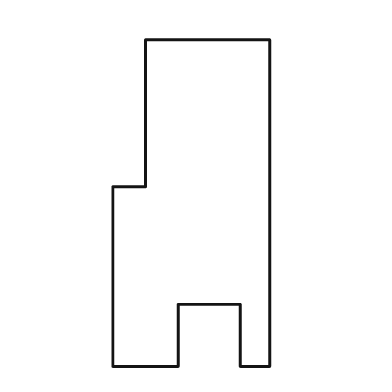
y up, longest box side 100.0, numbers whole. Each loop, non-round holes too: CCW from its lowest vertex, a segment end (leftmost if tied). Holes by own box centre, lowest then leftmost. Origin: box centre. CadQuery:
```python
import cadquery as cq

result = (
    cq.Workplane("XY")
    .moveTo(-24.0, -50.0)
    .lineTo(-4.0, -50.0)
    .lineTo(-4.0, -31.0)
    .lineTo(15.0, -31.0)
    .lineTo(15.0, -50.0)
    .lineTo(24.0, -50.0)
    .lineTo(24.0, 50.0)
    .lineTo(-14.0, 50.0)
    .lineTo(-14.0, 5.0)
    .lineTo(-24.0, 5.0)
    .close()
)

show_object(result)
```